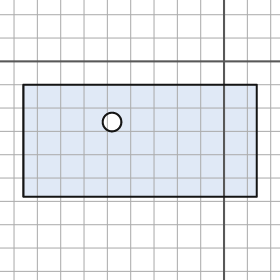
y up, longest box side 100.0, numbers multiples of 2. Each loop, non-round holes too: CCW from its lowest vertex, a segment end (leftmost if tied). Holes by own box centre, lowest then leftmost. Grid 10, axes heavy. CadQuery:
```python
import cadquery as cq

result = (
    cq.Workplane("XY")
    .moveTo(-86.0, -58.0)
    .lineTo(14.0, -58.0)
    .lineTo(14.0, -10.0)
    .lineTo(-86.0, -10.0)
    .close()
    .moveTo(-48.0, -26.0)
    .circle(4.0)
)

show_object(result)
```